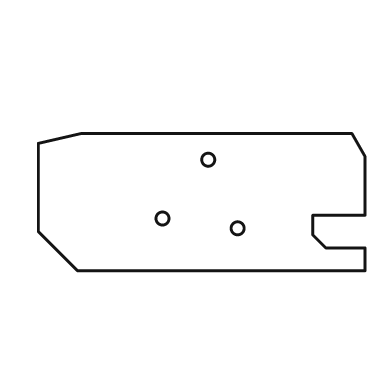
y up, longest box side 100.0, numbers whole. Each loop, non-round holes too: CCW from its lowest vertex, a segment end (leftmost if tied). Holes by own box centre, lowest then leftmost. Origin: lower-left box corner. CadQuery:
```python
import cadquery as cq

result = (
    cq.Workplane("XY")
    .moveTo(12.0, 0.0)
    .lineTo(100.0, 0.0)
    .lineTo(100.0, 7.0)
    .lineTo(88.0, 7.0)
    .lineTo(84.0, 11.0)
    .lineTo(84.0, 17.0)
    .lineTo(100.0, 17.0)
    .lineTo(100.0, 35.0)
    .lineTo(96.0, 42.0)
    .lineTo(13.0, 42.0)
    .lineTo(0.0, 39.0)
    .lineTo(0.0, 12.0)
    .close()
    .moveTo(61.0, 13.0)
    .circle(2.0)
    .moveTo(38.0, 16.0)
    .circle(2.0)
    .moveTo(52.0, 34.0)
    .circle(2.0)
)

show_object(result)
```